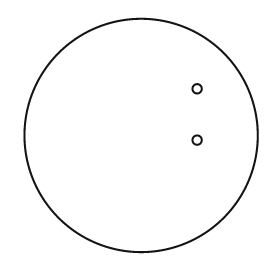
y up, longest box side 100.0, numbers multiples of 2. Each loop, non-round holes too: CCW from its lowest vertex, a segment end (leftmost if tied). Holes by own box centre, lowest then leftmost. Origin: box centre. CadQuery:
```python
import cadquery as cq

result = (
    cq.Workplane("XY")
    .moveTo(0.0, 0.0)
    .circle(50.0)
    .moveTo(24.0, -2.0)
    .circle(2.0)
    .moveTo(24.0, 20.0)
    .circle(2.0)
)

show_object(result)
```